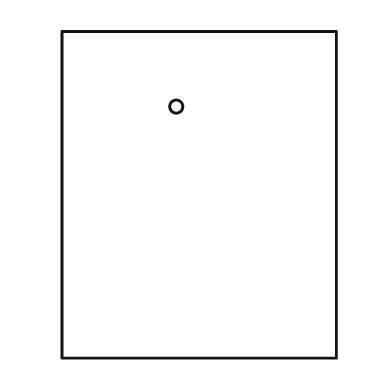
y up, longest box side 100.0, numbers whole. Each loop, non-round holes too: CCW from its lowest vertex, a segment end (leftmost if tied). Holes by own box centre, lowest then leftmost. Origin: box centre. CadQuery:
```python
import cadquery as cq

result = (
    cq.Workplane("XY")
    .moveTo(-42.0, -50.0)
    .lineTo(42.0, -50.0)
    .lineTo(42.0, 50.0)
    .lineTo(-42.0, 50.0)
    .close()
    .moveTo(-7.0, 27.0)
    .circle(2.0)
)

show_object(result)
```